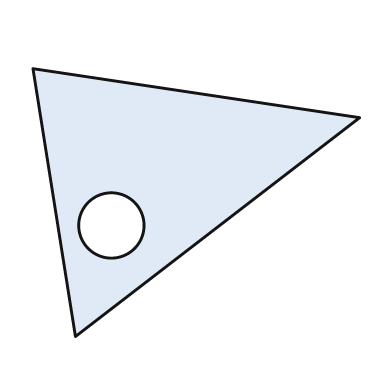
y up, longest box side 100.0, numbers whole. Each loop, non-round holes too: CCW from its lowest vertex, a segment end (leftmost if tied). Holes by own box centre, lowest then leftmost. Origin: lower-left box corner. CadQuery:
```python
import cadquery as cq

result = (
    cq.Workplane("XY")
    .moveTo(13.0, 0.0)
    .lineTo(100.0, 67.0)
    .lineTo(0.0, 82.0)
    .close()
    .moveTo(24.0, 34.0)
    .circle(10.0)
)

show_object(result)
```